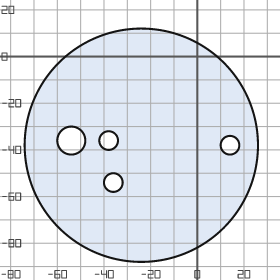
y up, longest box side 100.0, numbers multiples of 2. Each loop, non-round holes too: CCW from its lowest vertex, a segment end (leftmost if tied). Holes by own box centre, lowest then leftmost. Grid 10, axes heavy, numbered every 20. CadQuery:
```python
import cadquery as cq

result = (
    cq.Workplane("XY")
    .moveTo(-24.0, -38.0)
    .circle(50.0)
    .moveTo(-36.0, -54.0)
    .circle(4.0)
    .moveTo(14.0, -38.0)
    .circle(4.0)
    .moveTo(-54.0, -36.0)
    .circle(6.0)
    .moveTo(-38.0, -36.0)
    .circle(4.0)
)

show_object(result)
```